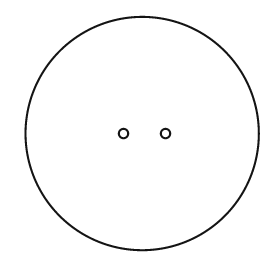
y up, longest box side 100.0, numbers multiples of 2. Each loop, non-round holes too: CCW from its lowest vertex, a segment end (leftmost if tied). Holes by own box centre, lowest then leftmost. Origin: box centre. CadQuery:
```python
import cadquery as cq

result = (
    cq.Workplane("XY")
    .moveTo(0.0, 0.0)
    .circle(50.0)
    .moveTo(-8.0, 0.0)
    .circle(2.0)
    .moveTo(10.0, 0.0)
    .circle(2.0)
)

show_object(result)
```